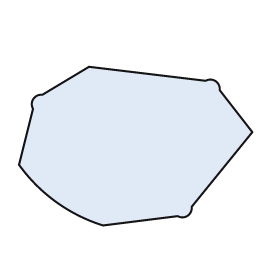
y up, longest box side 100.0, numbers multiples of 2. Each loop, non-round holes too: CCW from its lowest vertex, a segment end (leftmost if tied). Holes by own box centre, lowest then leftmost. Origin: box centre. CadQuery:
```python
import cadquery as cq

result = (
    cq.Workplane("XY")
    .moveTo(-14.0, -34.0)
    .lineTo(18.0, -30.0)
    .threePointArc((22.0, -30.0), (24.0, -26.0))
    .lineTo(50.0, 6.0)
    .lineTo(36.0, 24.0)
    .threePointArc((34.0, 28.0), (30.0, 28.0))
    .lineTo(-20.0, 34.0)
    .lineTo(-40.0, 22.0)
    .threePointArc((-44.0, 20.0), (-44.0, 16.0))
    .lineTo(-50.0, -8.0)
    .threePointArc((-34.0, -24.0), (-14.0, -34.0))
    .close()
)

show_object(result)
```